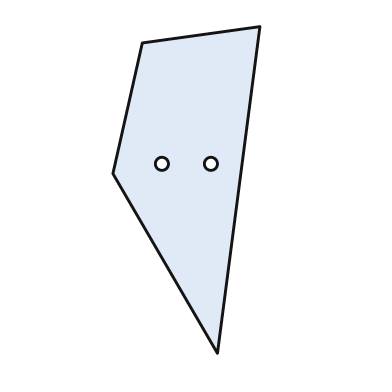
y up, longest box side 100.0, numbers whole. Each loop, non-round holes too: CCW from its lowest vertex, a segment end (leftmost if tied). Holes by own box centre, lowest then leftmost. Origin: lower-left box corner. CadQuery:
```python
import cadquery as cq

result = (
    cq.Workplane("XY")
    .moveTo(32.0, 0.0)
    .lineTo(45.0, 100.0)
    .lineTo(9.0, 95.0)
    .lineTo(0.0, 55.0)
    .close()
    .moveTo(15.0, 58.0)
    .circle(2.0)
    .moveTo(30.0, 58.0)
    .circle(2.0)
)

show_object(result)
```